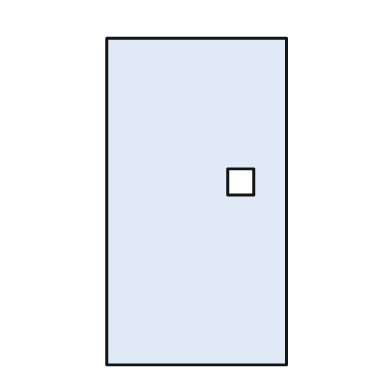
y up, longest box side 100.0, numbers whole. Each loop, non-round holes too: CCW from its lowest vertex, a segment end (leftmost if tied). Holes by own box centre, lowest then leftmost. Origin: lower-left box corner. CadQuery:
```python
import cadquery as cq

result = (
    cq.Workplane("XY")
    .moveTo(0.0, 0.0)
    .lineTo(55.0, 0.0)
    .lineTo(55.0, 100.0)
    .lineTo(0.0, 100.0)
    .close()
    .moveTo(37.0, 52.0)
    .lineTo(45.0, 52.0)
    .lineTo(45.0, 60.0)
    .lineTo(37.0, 60.0)
    .close()
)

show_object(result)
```